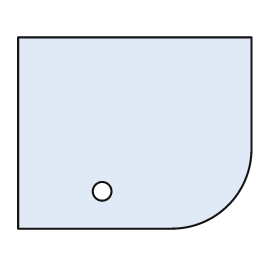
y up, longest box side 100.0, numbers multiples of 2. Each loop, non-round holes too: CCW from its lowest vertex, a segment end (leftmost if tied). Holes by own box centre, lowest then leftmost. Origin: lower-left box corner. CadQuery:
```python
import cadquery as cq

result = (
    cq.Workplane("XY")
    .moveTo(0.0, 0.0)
    .lineTo(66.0, 0.0)
    .threePointArc((90.0, 10.0), (100.0, 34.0))
    .lineTo(100.0, 82.0)
    .lineTo(0.0, 82.0)
    .close()
    .moveTo(36.0, 16.0)
    .circle(4.0)
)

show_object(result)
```